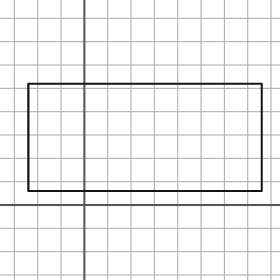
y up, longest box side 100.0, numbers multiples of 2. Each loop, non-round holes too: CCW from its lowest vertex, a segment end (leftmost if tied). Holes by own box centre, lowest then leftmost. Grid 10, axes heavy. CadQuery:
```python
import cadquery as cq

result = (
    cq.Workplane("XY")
    .moveTo(-24.0, 6.0)
    .lineTo(76.0, 6.0)
    .lineTo(76.0, 52.0)
    .lineTo(-24.0, 52.0)
    .close()
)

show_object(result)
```